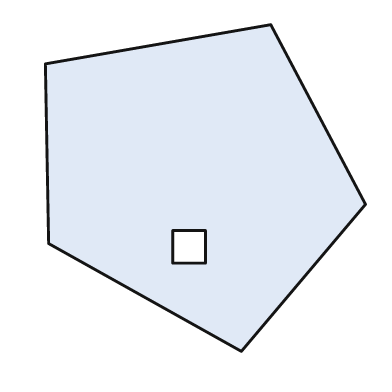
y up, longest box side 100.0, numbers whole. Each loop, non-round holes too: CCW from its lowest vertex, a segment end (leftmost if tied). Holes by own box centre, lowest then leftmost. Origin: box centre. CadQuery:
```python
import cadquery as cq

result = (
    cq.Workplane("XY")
    .moveTo(11.0, -50.0)
    .lineTo(49.0, -5.0)
    .lineTo(20.0, 50.0)
    .lineTo(-49.0, 38.0)
    .lineTo(-48.0, -17.0)
    .close()
    .moveTo(-10.0, -23.0)
    .lineTo(0.0, -23.0)
    .lineTo(0.0, -13.0)
    .lineTo(-10.0, -13.0)
    .close()
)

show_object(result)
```